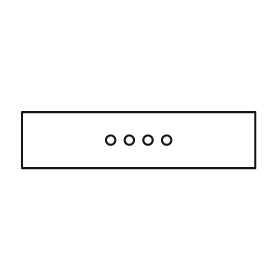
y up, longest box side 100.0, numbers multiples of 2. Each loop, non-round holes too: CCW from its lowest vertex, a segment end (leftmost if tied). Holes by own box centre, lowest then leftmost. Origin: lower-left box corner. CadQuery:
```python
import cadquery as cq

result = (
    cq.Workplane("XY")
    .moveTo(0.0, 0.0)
    .lineTo(100.0, 0.0)
    .lineTo(100.0, 24.0)
    .lineTo(0.0, 24.0)
    .close()
    .moveTo(38.0, 12.0)
    .circle(2.0)
    .moveTo(46.0, 12.0)
    .circle(2.0)
    .moveTo(54.0, 12.0)
    .circle(2.0)
    .moveTo(62.0, 12.0)
    .circle(2.0)
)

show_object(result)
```